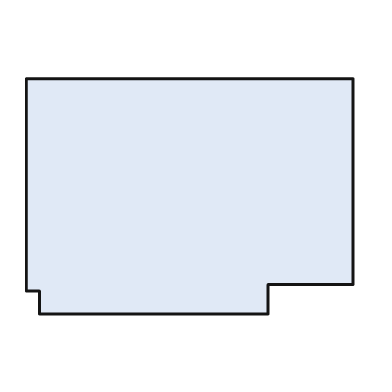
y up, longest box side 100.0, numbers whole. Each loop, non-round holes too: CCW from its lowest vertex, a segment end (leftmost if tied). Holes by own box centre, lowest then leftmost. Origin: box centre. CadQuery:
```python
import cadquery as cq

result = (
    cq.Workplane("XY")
    .moveTo(-46.0, -36.0)
    .lineTo(24.0, -36.0)
    .lineTo(24.0, -27.0)
    .lineTo(50.0, -27.0)
    .lineTo(50.0, 36.0)
    .lineTo(-50.0, 36.0)
    .lineTo(-50.0, -29.0)
    .lineTo(-46.0, -29.0)
    .close()
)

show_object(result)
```